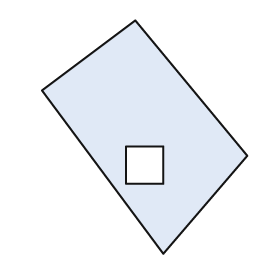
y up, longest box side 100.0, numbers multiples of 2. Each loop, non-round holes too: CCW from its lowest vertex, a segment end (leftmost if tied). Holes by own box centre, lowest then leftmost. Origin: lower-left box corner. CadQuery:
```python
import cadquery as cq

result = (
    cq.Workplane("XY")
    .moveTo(52.0, 0.0)
    .lineTo(88.0, 42.0)
    .lineTo(40.0, 100.0)
    .lineTo(0.0, 70.0)
    .close()
    .moveTo(36.0, 30.0)
    .lineTo(52.0, 30.0)
    .lineTo(52.0, 46.0)
    .lineTo(36.0, 46.0)
    .close()
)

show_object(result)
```